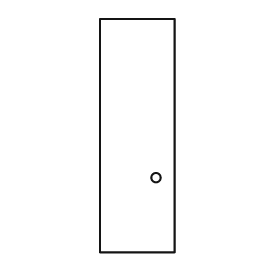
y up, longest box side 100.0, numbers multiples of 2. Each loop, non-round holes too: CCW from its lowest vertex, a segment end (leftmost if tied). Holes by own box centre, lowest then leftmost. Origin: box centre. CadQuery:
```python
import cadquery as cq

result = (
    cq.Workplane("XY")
    .moveTo(-16.0, -50.0)
    .lineTo(16.0, -50.0)
    .lineTo(16.0, 50.0)
    .lineTo(-16.0, 50.0)
    .close()
    .moveTo(8.0, -18.0)
    .circle(2.0)
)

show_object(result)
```